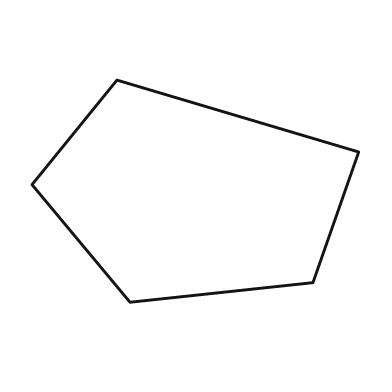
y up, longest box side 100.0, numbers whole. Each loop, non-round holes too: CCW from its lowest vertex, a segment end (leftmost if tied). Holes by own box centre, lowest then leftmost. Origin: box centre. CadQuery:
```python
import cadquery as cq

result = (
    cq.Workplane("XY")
    .moveTo(-20.0, -34.0)
    .lineTo(36.0, -28.0)
    .lineTo(50.0, 12.0)
    .lineTo(-24.0, 34.0)
    .lineTo(-50.0, 2.0)
    .close()
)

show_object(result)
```